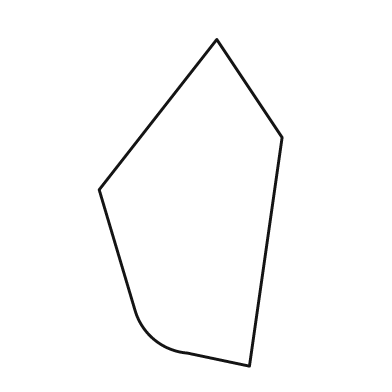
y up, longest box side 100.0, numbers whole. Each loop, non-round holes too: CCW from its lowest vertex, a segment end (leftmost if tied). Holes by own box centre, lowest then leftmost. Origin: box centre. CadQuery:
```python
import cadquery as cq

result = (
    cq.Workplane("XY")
    .moveTo(18.0, -50.0)
    .lineTo(28.0, 20.0)
    .lineTo(8.0, 50.0)
    .lineTo(-28.0, 4.0)
    .lineTo(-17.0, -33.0)
    .threePointArc((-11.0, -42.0), (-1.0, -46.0))
    .close()
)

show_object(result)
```